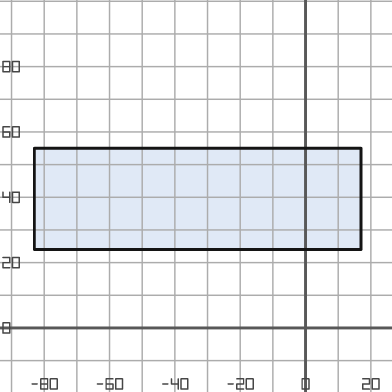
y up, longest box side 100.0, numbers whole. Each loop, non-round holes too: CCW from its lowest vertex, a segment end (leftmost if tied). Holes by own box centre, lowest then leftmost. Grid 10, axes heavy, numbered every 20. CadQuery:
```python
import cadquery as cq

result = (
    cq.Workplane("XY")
    .moveTo(-83.0, 24.0)
    .lineTo(17.0, 24.0)
    .lineTo(17.0, 55.0)
    .lineTo(-83.0, 55.0)
    .close()
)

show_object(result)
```